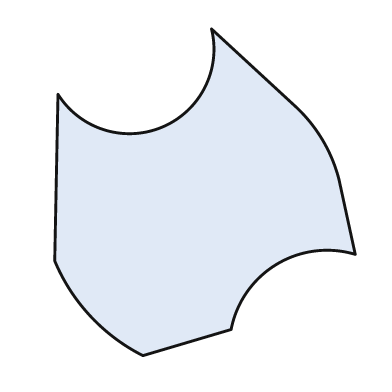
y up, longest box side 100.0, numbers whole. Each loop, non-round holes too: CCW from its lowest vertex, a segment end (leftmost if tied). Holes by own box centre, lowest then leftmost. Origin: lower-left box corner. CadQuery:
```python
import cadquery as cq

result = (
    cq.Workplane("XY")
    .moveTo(27.0, 0.0)
    .lineTo(54.0, 8.0)
    .threePointArc((68.0, 28.0), (92.0, 31.0))
    .lineTo(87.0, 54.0)
    .threePointArc((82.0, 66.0), (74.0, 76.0))
    .lineTo(48.0, 100.0)
    .threePointArc((33.0, 70.0), (1.0, 80.0))
    .lineTo(0.0, 29.0)
    .threePointArc((11.0, 12.0), (27.0, 0.0))
    .close()
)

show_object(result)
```